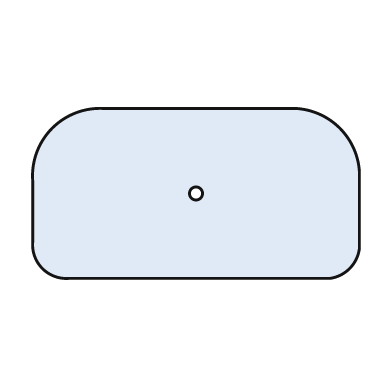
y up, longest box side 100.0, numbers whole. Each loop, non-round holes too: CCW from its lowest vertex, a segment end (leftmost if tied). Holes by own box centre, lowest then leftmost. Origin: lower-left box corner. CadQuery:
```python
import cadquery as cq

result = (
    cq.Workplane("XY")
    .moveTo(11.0, 0.0)
    .lineTo(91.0, 0.0)
    .threePointArc((97.0, 3.0), (100.0, 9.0))
    .lineTo(100.0, 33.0)
    .threePointArc((94.0, 46.0), (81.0, 52.0))
    .lineTo(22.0, 52.0)
    .threePointArc((6.0, 46.0), (0.0, 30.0))
    .lineTo(0.0, 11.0)
    .threePointArc((3.0, 3.0), (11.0, 0.0))
    .close()
    .moveTo(50.0, 26.0)
    .circle(2.0)
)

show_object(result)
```